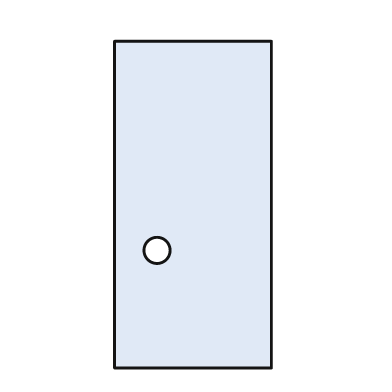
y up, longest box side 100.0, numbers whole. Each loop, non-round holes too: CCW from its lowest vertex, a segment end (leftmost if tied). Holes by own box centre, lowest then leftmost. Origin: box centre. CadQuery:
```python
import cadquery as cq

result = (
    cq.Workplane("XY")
    .moveTo(-24.0, -50.0)
    .lineTo(24.0, -50.0)
    .lineTo(24.0, 50.0)
    .lineTo(-24.0, 50.0)
    .close()
    .moveTo(-11.0, -14.0)
    .circle(4.0)
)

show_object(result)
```